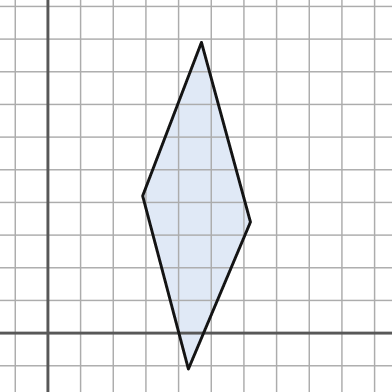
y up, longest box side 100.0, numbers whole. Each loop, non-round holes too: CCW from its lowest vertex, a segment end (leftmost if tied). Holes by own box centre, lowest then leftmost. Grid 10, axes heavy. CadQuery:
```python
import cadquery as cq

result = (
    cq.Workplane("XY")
    .moveTo(43.0, -11.0)
    .lineTo(62.0, 34.0)
    .lineTo(47.0, 89.0)
    .lineTo(29.0, 42.0)
    .close()
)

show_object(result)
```